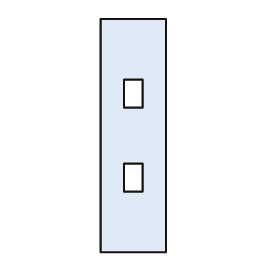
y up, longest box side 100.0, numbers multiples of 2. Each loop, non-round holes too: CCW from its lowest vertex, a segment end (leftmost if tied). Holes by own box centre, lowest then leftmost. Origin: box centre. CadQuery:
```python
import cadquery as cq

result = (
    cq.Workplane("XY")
    .moveTo(-14.0, -50.0)
    .lineTo(14.0, -50.0)
    .lineTo(14.0, 50.0)
    .lineTo(-14.0, 50.0)
    .close()
    .moveTo(-4.0, -24.0)
    .lineTo(4.0, -24.0)
    .lineTo(4.0, -12.0)
    .lineTo(-4.0, -12.0)
    .close()
    .moveTo(-4.0, 12.0)
    .lineTo(4.0, 12.0)
    .lineTo(4.0, 24.0)
    .lineTo(-4.0, 24.0)
    .close()
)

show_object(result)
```